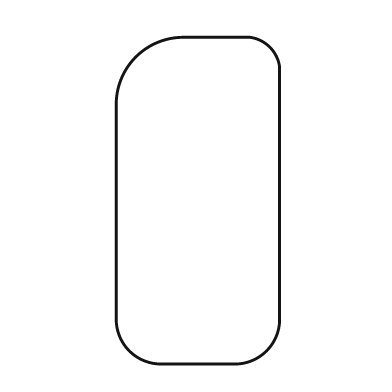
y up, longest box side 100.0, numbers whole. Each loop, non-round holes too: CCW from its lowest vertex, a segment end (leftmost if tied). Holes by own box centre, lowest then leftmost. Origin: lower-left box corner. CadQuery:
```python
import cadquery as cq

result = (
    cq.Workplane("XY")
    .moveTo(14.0, 0.0)
    .lineTo(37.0, 0.0)
    .threePointArc((46.0, 4.0), (50.0, 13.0))
    .lineTo(50.0, 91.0)
    .threePointArc((47.0, 97.0), (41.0, 100.0))
    .lineTo(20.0, 100.0)
    .threePointArc((6.0, 94.0), (0.0, 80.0))
    .lineTo(0.0, 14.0)
    .threePointArc((4.0, 4.0), (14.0, 0.0))
    .close()
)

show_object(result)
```